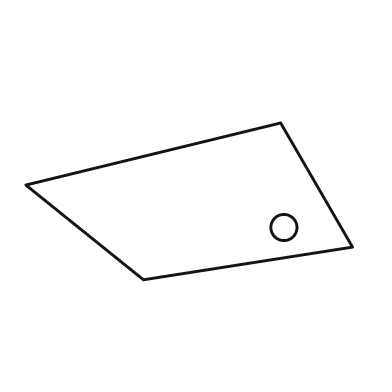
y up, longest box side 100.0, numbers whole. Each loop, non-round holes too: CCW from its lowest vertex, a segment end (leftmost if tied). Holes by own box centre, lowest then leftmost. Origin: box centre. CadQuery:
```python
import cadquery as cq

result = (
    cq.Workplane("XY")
    .moveTo(-14.0, -24.0)
    .lineTo(50.0, -14.0)
    .lineTo(28.0, 24.0)
    .lineTo(-50.0, 5.0)
    .close()
    .moveTo(29.0, -8.0)
    .circle(4.0)
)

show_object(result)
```